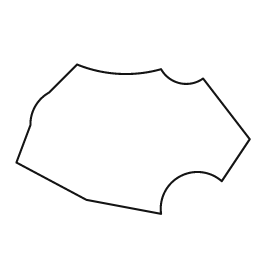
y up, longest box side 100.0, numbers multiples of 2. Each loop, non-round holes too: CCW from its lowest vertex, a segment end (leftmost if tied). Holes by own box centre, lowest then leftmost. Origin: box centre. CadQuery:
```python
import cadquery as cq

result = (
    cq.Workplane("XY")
    .moveTo(12.0, -32.0)
    .threePointArc((20.0, -16.0), (38.0, -18.0))
    .lineTo(50.0, 0.0)
    .lineTo(30.0, 26.0)
    .threePointArc((20.0, 24.0), (12.0, 30.0))
    .threePointArc((-6.0, 28.0), (-24.0, 32.0))
    .lineTo(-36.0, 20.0)
    .threePointArc((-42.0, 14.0), (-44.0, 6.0))
    .lineTo(-50.0, -10.0)
    .lineTo(-20.0, -26.0)
    .close()
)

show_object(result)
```